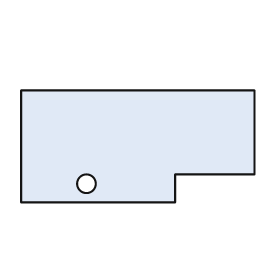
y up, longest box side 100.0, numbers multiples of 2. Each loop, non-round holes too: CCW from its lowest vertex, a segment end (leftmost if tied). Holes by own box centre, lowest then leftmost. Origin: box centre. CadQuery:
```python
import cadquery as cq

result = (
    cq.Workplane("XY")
    .moveTo(-50.0, -24.0)
    .lineTo(16.0, -24.0)
    .lineTo(16.0, -12.0)
    .lineTo(50.0, -12.0)
    .lineTo(50.0, 24.0)
    .lineTo(-50.0, 24.0)
    .close()
    .moveTo(-22.0, -16.0)
    .circle(4.0)
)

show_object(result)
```